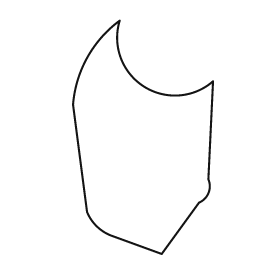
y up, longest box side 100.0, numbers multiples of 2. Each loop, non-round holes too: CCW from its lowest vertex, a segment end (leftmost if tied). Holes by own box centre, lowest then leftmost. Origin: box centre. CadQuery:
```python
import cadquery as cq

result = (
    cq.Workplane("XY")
    .moveTo(8.0, -50.0)
    .lineTo(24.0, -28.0)
    .threePointArc((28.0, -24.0), (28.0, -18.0))
    .lineTo(30.0, 24.0)
    .threePointArc((0.0, 22.0), (-10.0, 50.0))
    .threePointArc((-24.0, 34.0), (-30.0, 14.0))
    .lineTo(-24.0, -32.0)
    .threePointArc((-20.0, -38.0), (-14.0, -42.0))
    .close()
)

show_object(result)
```